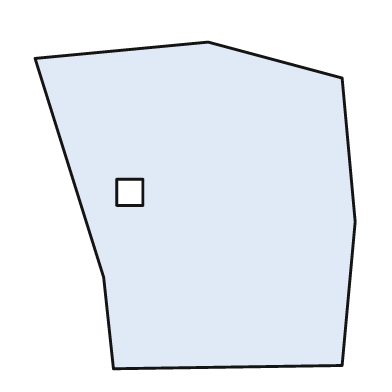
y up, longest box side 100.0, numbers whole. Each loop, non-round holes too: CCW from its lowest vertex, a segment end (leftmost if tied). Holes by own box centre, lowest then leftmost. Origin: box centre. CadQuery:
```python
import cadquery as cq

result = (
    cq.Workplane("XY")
    .moveTo(-25.0, -50.0)
    .lineTo(45.0, -49.0)
    .lineTo(49.0, -5.0)
    .lineTo(45.0, 39.0)
    .lineTo(4.0, 50.0)
    .lineTo(-49.0, 45.0)
    .lineTo(-28.0, -22.0)
    .close()
    .moveTo(-24.0, 0.0)
    .lineTo(-16.0, 0.0)
    .lineTo(-16.0, 8.0)
    .lineTo(-24.0, 8.0)
    .close()
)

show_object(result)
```